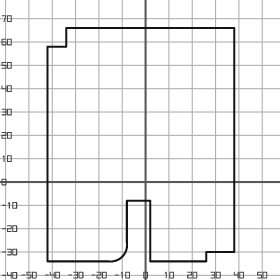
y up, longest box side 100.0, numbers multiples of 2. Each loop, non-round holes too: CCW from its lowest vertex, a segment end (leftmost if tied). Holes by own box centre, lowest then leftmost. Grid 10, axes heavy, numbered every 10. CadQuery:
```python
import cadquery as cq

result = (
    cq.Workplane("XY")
    .moveTo(-42.0, -34.0)
    .lineTo(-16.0, -34.0)
    .threePointArc((-10.0, -32.0), (-8.0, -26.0))
    .lineTo(-8.0, -8.0)
    .lineTo(2.0, -8.0)
    .lineTo(2.0, -34.0)
    .lineTo(26.0, -34.0)
    .lineTo(26.0, -30.0)
    .lineTo(38.0, -30.0)
    .lineTo(38.0, 66.0)
    .lineTo(-34.0, 66.0)
    .lineTo(-34.0, 58.0)
    .lineTo(-42.0, 58.0)
    .close()
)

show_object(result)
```